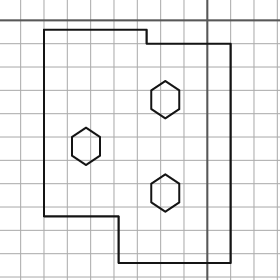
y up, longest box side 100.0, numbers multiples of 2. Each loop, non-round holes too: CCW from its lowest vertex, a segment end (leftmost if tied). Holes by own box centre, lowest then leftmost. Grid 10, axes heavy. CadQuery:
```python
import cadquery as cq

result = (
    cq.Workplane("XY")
    .moveTo(-38.0, -104.0)
    .lineTo(10.0, -104.0)
    .lineTo(10.0, -10.0)
    .lineTo(-26.0, -10.0)
    .lineTo(-26.0, -4.0)
    .lineTo(-70.0, -4.0)
    .lineTo(-70.0, -84.0)
    .lineTo(-38.0, -84.0)
    .close()
    .moveTo(-18.0, -82.0)
    .lineTo(-12.0, -78.0)
    .lineTo(-12.0, -70.0)
    .lineTo(-18.0, -66.0)
    .lineTo(-24.0, -70.0)
    .lineTo(-24.0, -78.0)
    .close()
    .moveTo(-52.0, -62.0)
    .lineTo(-46.0, -58.0)
    .lineTo(-46.0, -50.0)
    .lineTo(-52.0, -46.0)
    .lineTo(-58.0, -50.0)
    .lineTo(-58.0, -58.0)
    .close()
    .moveTo(-18.0, -42.0)
    .lineTo(-12.0, -38.0)
    .lineTo(-12.0, -30.0)
    .lineTo(-18.0, -26.0)
    .lineTo(-24.0, -30.0)
    .lineTo(-24.0, -38.0)
    .close()
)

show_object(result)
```